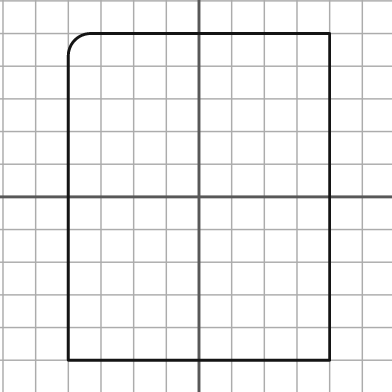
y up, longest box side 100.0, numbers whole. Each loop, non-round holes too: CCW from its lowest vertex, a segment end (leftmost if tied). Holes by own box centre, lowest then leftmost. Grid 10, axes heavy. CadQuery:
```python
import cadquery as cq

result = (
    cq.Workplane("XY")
    .moveTo(-40.0, -50.0)
    .lineTo(40.0, -50.0)
    .lineTo(40.0, 50.0)
    .lineTo(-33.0, 50.0)
    .threePointArc((-38.0, 48.0), (-40.0, 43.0))
    .close()
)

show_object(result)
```